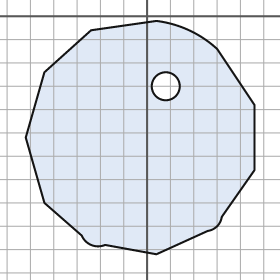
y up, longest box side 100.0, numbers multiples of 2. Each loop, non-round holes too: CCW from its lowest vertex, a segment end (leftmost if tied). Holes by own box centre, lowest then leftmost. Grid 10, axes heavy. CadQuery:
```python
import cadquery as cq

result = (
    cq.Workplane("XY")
    .moveTo(4.0, -102.0)
    .lineTo(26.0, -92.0)
    .threePointArc((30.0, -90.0), (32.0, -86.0))
    .lineTo(46.0, -66.0)
    .lineTo(46.0, -38.0)
    .lineTo(30.0, -14.0)
    .threePointArc((18.0, -6.0), (4.0, -2.0))
    .lineTo(-24.0, -6.0)
    .lineTo(-44.0, -24.0)
    .lineTo(-52.0, -52.0)
    .lineTo(-44.0, -80.0)
    .lineTo(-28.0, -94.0)
    .threePointArc((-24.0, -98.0), (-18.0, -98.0))
    .close()
    .moveTo(8.0, -30.0)
    .circle(6.0)
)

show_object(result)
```